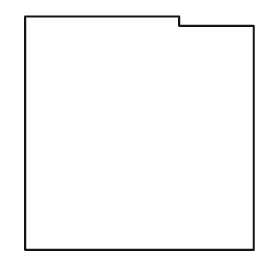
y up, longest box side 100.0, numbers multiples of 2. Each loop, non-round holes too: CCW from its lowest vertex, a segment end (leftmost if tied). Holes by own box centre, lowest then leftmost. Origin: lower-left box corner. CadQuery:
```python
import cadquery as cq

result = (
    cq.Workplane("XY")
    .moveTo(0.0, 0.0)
    .lineTo(98.0, 0.0)
    .lineTo(98.0, 96.0)
    .lineTo(66.0, 96.0)
    .lineTo(66.0, 100.0)
    .lineTo(0.0, 100.0)
    .close()
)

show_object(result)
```